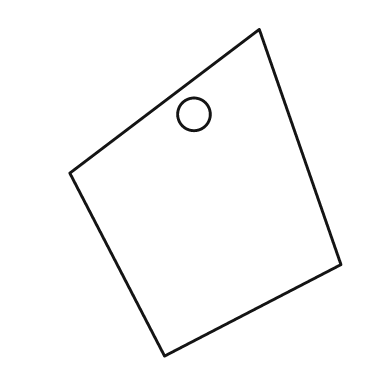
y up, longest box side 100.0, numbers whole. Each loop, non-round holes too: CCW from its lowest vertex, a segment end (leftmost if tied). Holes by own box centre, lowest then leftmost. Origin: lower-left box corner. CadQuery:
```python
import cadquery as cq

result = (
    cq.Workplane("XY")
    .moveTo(29.0, 0.0)
    .lineTo(83.0, 28.0)
    .lineTo(58.0, 100.0)
    .lineTo(0.0, 56.0)
    .close()
    .moveTo(38.0, 74.0)
    .circle(5.0)
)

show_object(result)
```